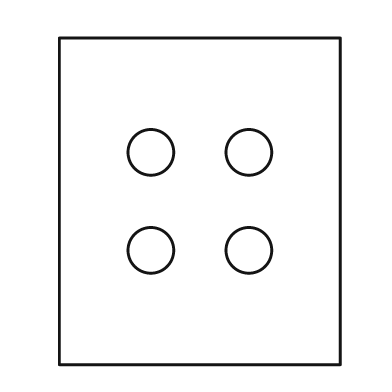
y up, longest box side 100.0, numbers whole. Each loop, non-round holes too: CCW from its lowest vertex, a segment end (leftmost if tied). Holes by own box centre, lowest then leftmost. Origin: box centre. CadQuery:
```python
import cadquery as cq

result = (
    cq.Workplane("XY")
    .moveTo(-43.0, -50.0)
    .lineTo(43.0, -50.0)
    .lineTo(43.0, 50.0)
    .lineTo(-43.0, 50.0)
    .close()
    .moveTo(-15.0, -15.0)
    .circle(7.0)
    .moveTo(15.0, -15.0)
    .circle(7.0)
    .moveTo(-15.0, 15.0)
    .circle(7.0)
    .moveTo(15.0, 15.0)
    .circle(7.0)
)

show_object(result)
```